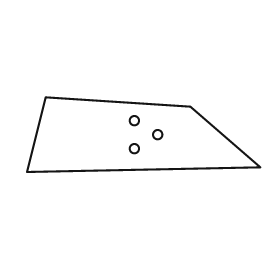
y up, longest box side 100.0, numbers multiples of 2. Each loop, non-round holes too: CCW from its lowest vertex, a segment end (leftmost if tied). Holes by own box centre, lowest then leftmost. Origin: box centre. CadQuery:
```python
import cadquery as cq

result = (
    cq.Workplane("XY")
    .moveTo(-50.0, -16.0)
    .lineTo(50.0, -14.0)
    .lineTo(20.0, 12.0)
    .lineTo(-42.0, 16.0)
    .close()
    .moveTo(-4.0, -6.0)
    .circle(2.0)
    .moveTo(6.0, 0.0)
    .circle(2.0)
    .moveTo(-4.0, 6.0)
    .circle(2.0)
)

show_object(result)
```